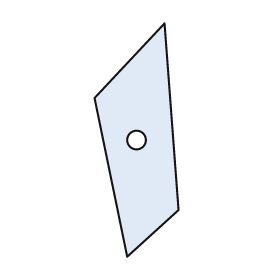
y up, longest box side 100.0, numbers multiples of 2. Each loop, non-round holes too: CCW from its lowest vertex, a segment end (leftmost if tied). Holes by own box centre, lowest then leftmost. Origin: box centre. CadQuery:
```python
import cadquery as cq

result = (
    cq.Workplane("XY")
    .moveTo(-4.0, -50.0)
    .lineTo(18.0, -30.0)
    .lineTo(12.0, 50.0)
    .lineTo(-18.0, 18.0)
    .close()
    .moveTo(0.0, 0.0)
    .circle(4.0)
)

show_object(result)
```